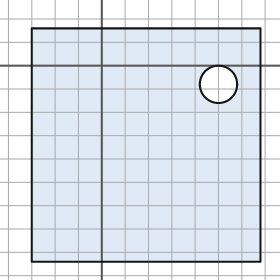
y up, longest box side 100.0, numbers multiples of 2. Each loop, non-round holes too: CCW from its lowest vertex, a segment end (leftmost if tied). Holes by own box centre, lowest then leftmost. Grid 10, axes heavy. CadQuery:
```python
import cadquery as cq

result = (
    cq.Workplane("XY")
    .moveTo(-30.0, -84.0)
    .lineTo(68.0, -84.0)
    .lineTo(68.0, 16.0)
    .lineTo(-30.0, 16.0)
    .close()
    .moveTo(50.0, -8.0)
    .circle(8.0)
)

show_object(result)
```